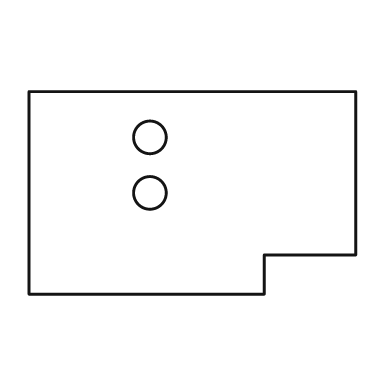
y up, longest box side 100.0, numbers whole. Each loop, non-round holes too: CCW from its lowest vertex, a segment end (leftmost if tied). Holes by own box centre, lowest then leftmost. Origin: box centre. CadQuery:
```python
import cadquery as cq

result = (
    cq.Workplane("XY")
    .moveTo(-50.0, -31.0)
    .lineTo(22.0, -31.0)
    .lineTo(22.0, -19.0)
    .lineTo(50.0, -19.0)
    .lineTo(50.0, 31.0)
    .lineTo(-50.0, 31.0)
    .close()
    .moveTo(-13.0, 0.0)
    .circle(5.0)
    .moveTo(-13.0, 17.0)
    .circle(5.0)
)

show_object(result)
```